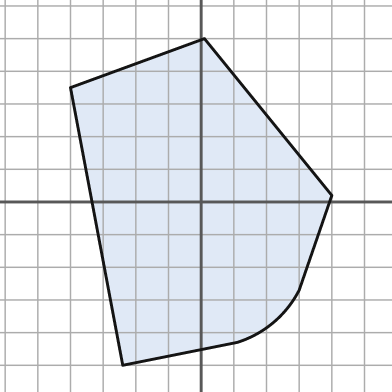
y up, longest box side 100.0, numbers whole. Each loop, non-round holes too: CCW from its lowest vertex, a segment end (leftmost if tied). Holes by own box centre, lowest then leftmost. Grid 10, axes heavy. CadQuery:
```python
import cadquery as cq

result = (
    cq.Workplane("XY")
    .moveTo(-24.0, -50.0)
    .lineTo(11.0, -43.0)
    .threePointArc((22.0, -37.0), (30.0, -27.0))
    .lineTo(40.0, 2.0)
    .lineTo(1.0, 50.0)
    .lineTo(-40.0, 35.0)
    .close()
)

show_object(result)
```